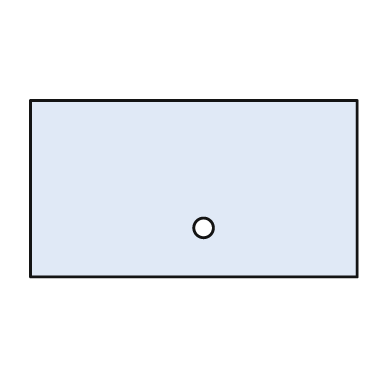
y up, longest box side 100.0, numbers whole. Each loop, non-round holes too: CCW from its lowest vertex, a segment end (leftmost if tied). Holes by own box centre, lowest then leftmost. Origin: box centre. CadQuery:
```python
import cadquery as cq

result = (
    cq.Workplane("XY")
    .moveTo(-50.0, -27.0)
    .lineTo(50.0, -27.0)
    .lineTo(50.0, 27.0)
    .lineTo(-50.0, 27.0)
    .close()
    .moveTo(3.0, -12.0)
    .circle(3.0)
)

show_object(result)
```